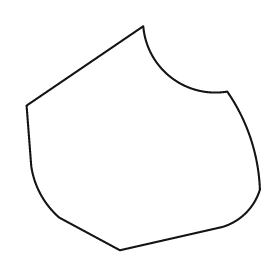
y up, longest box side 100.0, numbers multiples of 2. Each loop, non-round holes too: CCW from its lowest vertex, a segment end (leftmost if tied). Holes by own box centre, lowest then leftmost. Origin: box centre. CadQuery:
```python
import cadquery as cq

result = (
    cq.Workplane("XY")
    .moveTo(-10.0, -48.0)
    .lineTo(34.0, -38.0)
    .threePointArc((44.0, -32.0), (50.0, -22.0))
    .threePointArc((46.0, 0.0), (36.0, 20.0))
    .threePointArc((12.0, 26.0), (0.0, 48.0))
    .lineTo(-50.0, 14.0)
    .lineTo(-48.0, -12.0)
    .threePointArc((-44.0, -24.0), (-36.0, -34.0))
    .close()
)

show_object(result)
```